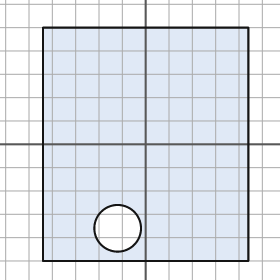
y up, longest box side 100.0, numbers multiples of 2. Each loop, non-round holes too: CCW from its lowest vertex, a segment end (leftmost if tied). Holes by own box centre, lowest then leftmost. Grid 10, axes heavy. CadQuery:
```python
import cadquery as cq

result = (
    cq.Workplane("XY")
    .moveTo(-44.0, -50.0)
    .lineTo(44.0, -50.0)
    .lineTo(44.0, 50.0)
    .lineTo(-44.0, 50.0)
    .close()
    .moveTo(-12.0, -36.0)
    .circle(10.0)
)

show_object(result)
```